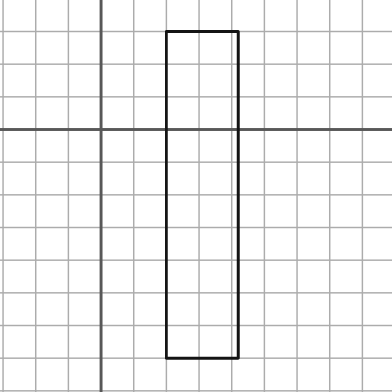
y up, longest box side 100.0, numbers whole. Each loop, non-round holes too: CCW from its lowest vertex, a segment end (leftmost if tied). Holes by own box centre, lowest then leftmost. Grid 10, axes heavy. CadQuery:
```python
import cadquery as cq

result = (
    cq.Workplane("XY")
    .moveTo(20.0, -70.0)
    .lineTo(42.0, -70.0)
    .lineTo(42.0, 30.0)
    .lineTo(20.0, 30.0)
    .close()
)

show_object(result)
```